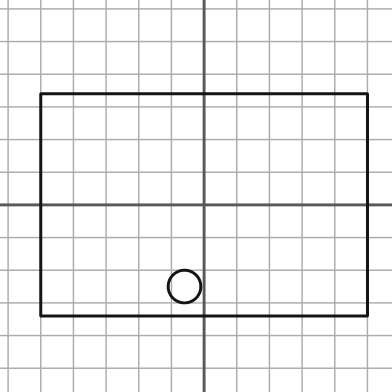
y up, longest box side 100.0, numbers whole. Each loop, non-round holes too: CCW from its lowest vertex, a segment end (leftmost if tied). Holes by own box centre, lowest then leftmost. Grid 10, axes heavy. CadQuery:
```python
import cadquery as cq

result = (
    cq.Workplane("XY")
    .moveTo(-50.0, -34.0)
    .lineTo(50.0, -34.0)
    .lineTo(50.0, 34.0)
    .lineTo(-50.0, 34.0)
    .close()
    .moveTo(-6.0, -25.0)
    .circle(5.0)
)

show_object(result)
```